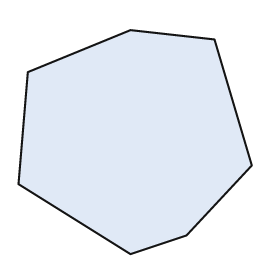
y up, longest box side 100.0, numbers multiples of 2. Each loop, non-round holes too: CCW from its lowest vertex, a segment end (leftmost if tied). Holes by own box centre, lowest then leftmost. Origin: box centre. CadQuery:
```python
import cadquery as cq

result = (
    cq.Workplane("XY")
    .moveTo(-2.0, -48.0)
    .lineTo(22.0, -40.0)
    .lineTo(50.0, -10.0)
    .lineTo(34.0, 44.0)
    .lineTo(-2.0, 48.0)
    .lineTo(-46.0, 30.0)
    .lineTo(-50.0, -18.0)
    .close()
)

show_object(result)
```